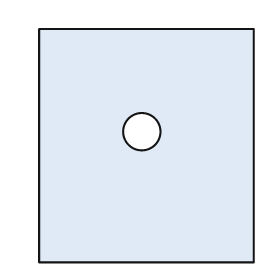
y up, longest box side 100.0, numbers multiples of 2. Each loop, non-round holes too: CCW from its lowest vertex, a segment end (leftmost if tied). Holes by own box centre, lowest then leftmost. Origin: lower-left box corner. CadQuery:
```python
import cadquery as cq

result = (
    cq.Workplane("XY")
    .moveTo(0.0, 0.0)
    .lineTo(92.0, 0.0)
    .lineTo(92.0, 100.0)
    .lineTo(0.0, 100.0)
    .close()
    .moveTo(44.0, 56.0)
    .circle(8.0)
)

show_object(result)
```